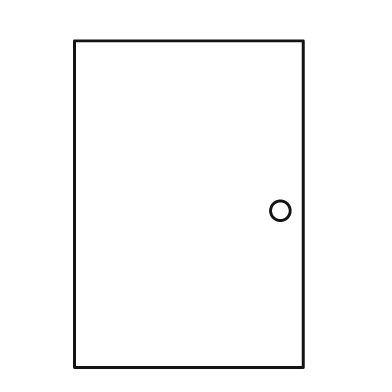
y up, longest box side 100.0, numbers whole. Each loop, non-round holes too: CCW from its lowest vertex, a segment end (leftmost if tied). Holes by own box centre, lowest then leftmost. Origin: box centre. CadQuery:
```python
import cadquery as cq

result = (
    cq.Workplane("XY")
    .moveTo(-35.0, -50.0)
    .lineTo(35.0, -50.0)
    .lineTo(35.0, 50.0)
    .lineTo(-35.0, 50.0)
    .close()
    .moveTo(28.0, -2.0)
    .circle(3.0)
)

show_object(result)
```